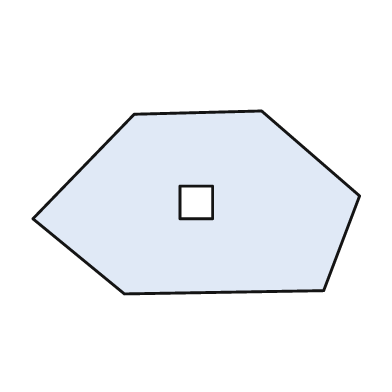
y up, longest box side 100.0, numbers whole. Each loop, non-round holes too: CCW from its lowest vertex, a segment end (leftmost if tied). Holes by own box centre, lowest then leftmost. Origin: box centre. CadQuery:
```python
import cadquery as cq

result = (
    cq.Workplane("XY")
    .moveTo(-22.0, -28.0)
    .lineTo(39.0, -27.0)
    .lineTo(50.0, 2.0)
    .lineTo(20.0, 28.0)
    .lineTo(-19.0, 27.0)
    .lineTo(-50.0, -5.0)
    .close()
    .moveTo(-5.0, -5.0)
    .lineTo(5.0, -5.0)
    .lineTo(5.0, 5.0)
    .lineTo(-5.0, 5.0)
    .close()
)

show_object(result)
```